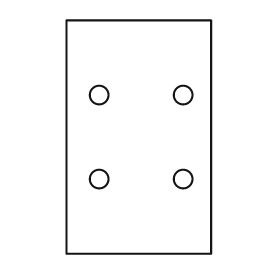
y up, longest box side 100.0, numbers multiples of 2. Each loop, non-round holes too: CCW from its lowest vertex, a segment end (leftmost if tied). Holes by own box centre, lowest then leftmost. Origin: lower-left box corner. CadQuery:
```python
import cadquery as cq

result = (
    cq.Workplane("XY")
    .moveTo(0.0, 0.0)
    .lineTo(62.0, 0.0)
    .lineTo(62.0, 100.0)
    .lineTo(0.0, 100.0)
    .close()
    .moveTo(14.0, 32.0)
    .circle(4.0)
    .moveTo(50.0, 32.0)
    .circle(4.0)
    .moveTo(14.0, 68.0)
    .circle(4.0)
    .moveTo(50.0, 68.0)
    .circle(4.0)
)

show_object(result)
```